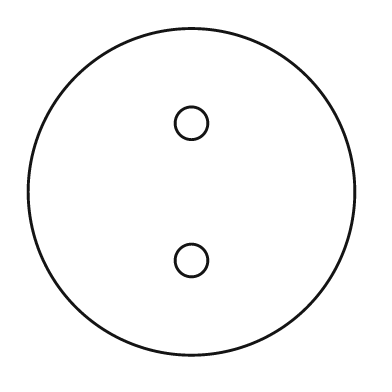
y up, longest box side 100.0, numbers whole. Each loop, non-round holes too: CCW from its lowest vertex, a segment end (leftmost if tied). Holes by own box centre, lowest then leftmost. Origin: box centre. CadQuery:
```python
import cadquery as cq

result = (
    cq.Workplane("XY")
    .moveTo(0.0, 0.0)
    .circle(50.0)
    .moveTo(0.0, -21.0)
    .circle(5.0)
    .moveTo(0.0, 21.0)
    .circle(5.0)
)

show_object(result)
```